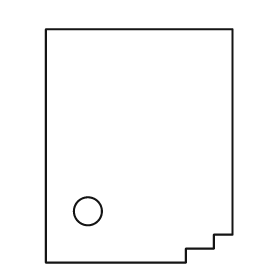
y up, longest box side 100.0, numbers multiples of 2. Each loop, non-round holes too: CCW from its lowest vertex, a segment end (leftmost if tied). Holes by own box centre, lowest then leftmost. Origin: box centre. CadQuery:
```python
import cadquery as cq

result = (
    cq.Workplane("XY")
    .moveTo(-40.0, -50.0)
    .lineTo(20.0, -50.0)
    .lineTo(20.0, -44.0)
    .lineTo(32.0, -44.0)
    .lineTo(32.0, -38.0)
    .lineTo(40.0, -38.0)
    .lineTo(40.0, 50.0)
    .lineTo(-40.0, 50.0)
    .close()
    .moveTo(-22.0, -28.0)
    .circle(6.0)
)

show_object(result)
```